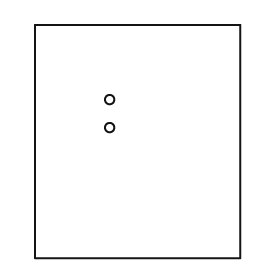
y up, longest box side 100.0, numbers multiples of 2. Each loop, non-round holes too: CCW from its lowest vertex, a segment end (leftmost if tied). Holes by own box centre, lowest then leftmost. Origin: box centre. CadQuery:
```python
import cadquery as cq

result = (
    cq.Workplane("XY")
    .moveTo(-44.0, -50.0)
    .lineTo(44.0, -50.0)
    .lineTo(44.0, 50.0)
    .lineTo(-44.0, 50.0)
    .close()
    .moveTo(-12.0, 6.0)
    .circle(2.0)
    .moveTo(-12.0, 18.0)
    .circle(2.0)
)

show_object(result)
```